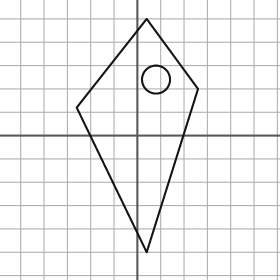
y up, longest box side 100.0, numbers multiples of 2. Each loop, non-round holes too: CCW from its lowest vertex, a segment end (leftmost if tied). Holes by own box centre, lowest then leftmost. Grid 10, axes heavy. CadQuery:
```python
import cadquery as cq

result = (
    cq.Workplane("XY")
    .moveTo(4.0, -50.0)
    .lineTo(26.0, 20.0)
    .lineTo(4.0, 50.0)
    .lineTo(-26.0, 12.0)
    .close()
    .moveTo(8.0, 24.0)
    .circle(6.0)
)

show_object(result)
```